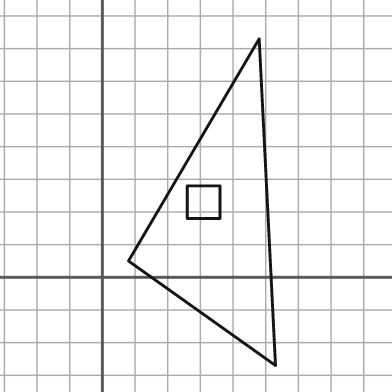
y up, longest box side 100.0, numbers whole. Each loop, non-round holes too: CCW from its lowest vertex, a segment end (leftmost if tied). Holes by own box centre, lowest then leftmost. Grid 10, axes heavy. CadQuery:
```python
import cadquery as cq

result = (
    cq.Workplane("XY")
    .moveTo(53.0, -27.0)
    .lineTo(48.0, 73.0)
    .lineTo(8.0, 5.0)
    .close()
    .moveTo(26.0, 18.0)
    .lineTo(36.0, 18.0)
    .lineTo(36.0, 28.0)
    .lineTo(26.0, 28.0)
    .close()
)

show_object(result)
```